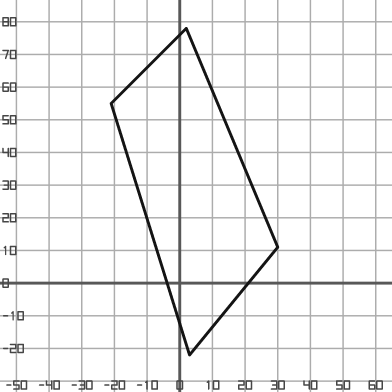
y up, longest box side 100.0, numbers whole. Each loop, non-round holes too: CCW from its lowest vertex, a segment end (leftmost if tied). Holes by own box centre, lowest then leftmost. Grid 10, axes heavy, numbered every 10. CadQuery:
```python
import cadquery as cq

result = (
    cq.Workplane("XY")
    .moveTo(3.0, -22.0)
    .lineTo(30.0, 11.0)
    .lineTo(2.0, 78.0)
    .lineTo(-21.0, 55.0)
    .close()
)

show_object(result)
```